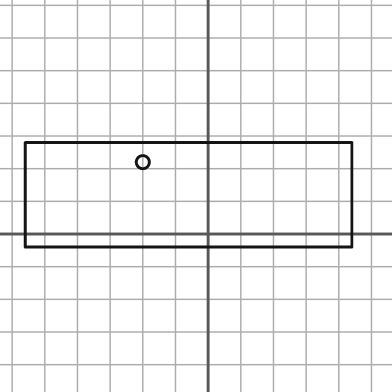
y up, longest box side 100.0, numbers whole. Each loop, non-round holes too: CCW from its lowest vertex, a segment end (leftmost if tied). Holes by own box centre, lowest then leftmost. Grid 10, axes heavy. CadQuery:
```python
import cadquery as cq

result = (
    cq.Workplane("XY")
    .moveTo(-56.0, -4.0)
    .lineTo(44.0, -4.0)
    .lineTo(44.0, 28.0)
    .lineTo(-56.0, 28.0)
    .close()
    .moveTo(-20.0, 22.0)
    .circle(2.0)
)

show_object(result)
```